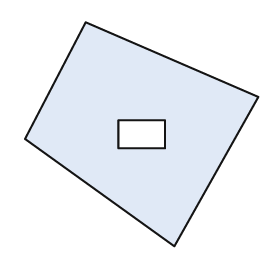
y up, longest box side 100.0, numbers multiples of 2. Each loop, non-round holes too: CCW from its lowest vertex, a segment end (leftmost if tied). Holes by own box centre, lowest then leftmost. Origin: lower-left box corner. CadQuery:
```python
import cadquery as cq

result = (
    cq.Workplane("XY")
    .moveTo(64.0, 0.0)
    .lineTo(100.0, 64.0)
    .lineTo(26.0, 96.0)
    .lineTo(0.0, 46.0)
    .close()
    .moveTo(40.0, 42.0)
    .lineTo(60.0, 42.0)
    .lineTo(60.0, 54.0)
    .lineTo(40.0, 54.0)
    .close()
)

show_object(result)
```